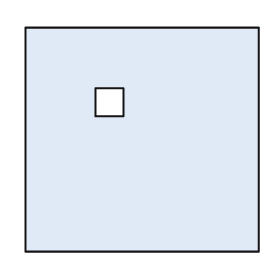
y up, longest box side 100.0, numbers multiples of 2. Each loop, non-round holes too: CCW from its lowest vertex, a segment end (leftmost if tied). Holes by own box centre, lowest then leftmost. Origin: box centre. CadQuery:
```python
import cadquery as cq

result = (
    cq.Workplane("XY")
    .moveTo(-50.0, -48.0)
    .lineTo(50.0, -48.0)
    .lineTo(50.0, 48.0)
    .lineTo(-50.0, 48.0)
    .close()
    .moveTo(-20.0, 10.0)
    .lineTo(-8.0, 10.0)
    .lineTo(-8.0, 22.0)
    .lineTo(-20.0, 22.0)
    .close()
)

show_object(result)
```